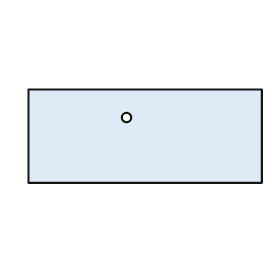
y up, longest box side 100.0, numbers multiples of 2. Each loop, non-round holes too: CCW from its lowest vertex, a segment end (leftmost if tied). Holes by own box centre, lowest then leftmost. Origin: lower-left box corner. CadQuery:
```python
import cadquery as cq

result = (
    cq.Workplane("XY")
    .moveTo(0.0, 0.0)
    .lineTo(100.0, 0.0)
    .lineTo(100.0, 40.0)
    .lineTo(0.0, 40.0)
    .close()
    .moveTo(42.0, 28.0)
    .circle(2.0)
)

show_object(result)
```